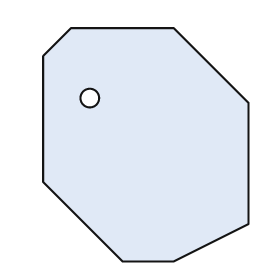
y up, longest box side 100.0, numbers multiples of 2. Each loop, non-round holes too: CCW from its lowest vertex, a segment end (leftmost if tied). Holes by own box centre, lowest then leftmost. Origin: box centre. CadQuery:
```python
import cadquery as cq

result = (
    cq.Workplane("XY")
    .moveTo(-10.0, -50.0)
    .lineTo(12.0, -50.0)
    .lineTo(44.0, -34.0)
    .lineTo(44.0, 18.0)
    .lineTo(12.0, 50.0)
    .lineTo(-32.0, 50.0)
    .lineTo(-44.0, 38.0)
    .lineTo(-44.0, -16.0)
    .close()
    .moveTo(-24.0, 20.0)
    .circle(4.0)
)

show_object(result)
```